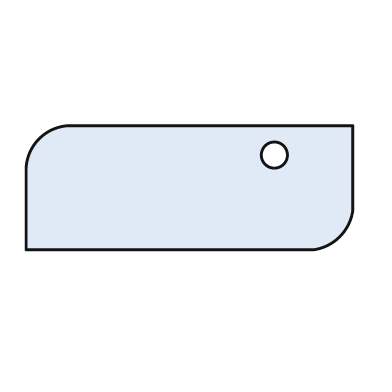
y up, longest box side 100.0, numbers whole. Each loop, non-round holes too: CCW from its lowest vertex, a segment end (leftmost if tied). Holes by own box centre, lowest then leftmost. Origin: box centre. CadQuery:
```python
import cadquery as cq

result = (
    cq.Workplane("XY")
    .moveTo(-50.0, -19.0)
    .lineTo(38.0, -19.0)
    .threePointArc((46.0, -15.0), (50.0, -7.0))
    .lineTo(50.0, 19.0)
    .lineTo(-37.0, 19.0)
    .threePointArc((-46.0, 15.0), (-50.0, 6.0))
    .close()
    .moveTo(26.0, 10.0)
    .circle(4.0)
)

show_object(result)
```